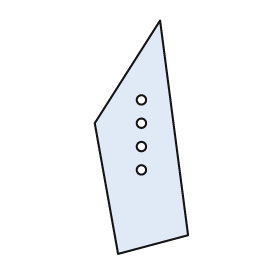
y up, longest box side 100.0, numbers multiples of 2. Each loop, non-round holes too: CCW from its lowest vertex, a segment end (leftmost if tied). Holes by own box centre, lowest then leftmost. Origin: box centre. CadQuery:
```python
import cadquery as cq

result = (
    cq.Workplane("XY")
    .moveTo(-10.0, -50.0)
    .lineTo(20.0, -42.0)
    .lineTo(8.0, 50.0)
    .lineTo(-20.0, 6.0)
    .close()
    .moveTo(0.0, -14.0)
    .circle(2.0)
    .moveTo(0.0, -4.0)
    .circle(2.0)
    .moveTo(0.0, 6.0)
    .circle(2.0)
    .moveTo(0.0, 16.0)
    .circle(2.0)
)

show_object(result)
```